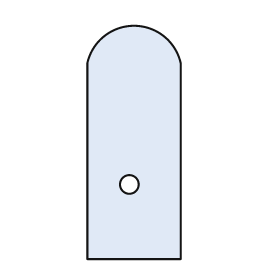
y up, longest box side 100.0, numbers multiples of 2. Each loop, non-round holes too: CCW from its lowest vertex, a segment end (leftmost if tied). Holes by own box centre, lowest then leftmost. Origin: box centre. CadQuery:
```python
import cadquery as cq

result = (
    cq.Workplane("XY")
    .moveTo(-20.0, -50.0)
    .lineTo(20.0, -50.0)
    .lineTo(20.0, 34.0)
    .threePointArc((0.0, 50.0), (-20.0, 34.0))
    .close()
    .moveTo(-2.0, -18.0)
    .circle(4.0)
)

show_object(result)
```